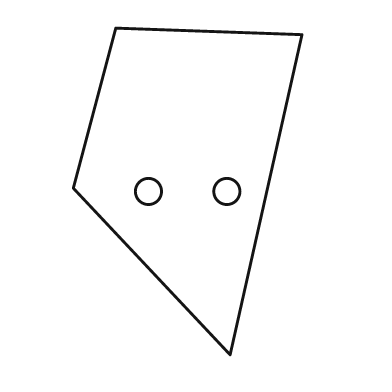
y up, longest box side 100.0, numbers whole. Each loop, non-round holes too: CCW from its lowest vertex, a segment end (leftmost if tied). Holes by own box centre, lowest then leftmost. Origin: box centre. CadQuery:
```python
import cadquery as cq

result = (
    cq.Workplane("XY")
    .moveTo(13.0, -50.0)
    .lineTo(35.0, 48.0)
    .lineTo(-22.0, 50.0)
    .lineTo(-35.0, 1.0)
    .close()
    .moveTo(-12.0, 0.0)
    .circle(4.0)
    .moveTo(12.0, 0.0)
    .circle(4.0)
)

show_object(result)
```